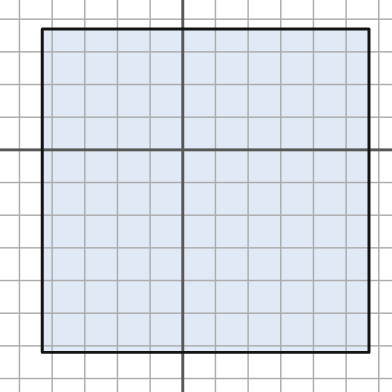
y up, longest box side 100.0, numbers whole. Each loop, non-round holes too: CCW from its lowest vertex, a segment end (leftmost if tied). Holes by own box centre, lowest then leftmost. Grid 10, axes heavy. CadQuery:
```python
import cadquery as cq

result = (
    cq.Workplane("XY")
    .moveTo(-43.0, -62.0)
    .lineTo(57.0, -62.0)
    .lineTo(57.0, 37.0)
    .lineTo(-43.0, 37.0)
    .close()
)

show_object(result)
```